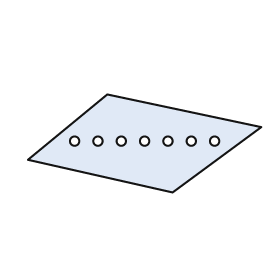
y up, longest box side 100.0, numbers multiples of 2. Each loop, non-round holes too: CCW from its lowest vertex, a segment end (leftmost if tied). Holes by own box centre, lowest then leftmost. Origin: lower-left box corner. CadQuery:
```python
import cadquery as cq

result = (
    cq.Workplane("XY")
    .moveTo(62.0, 0.0)
    .lineTo(100.0, 28.0)
    .lineTo(34.0, 42.0)
    .lineTo(0.0, 14.0)
    .close()
    .moveTo(20.0, 22.0)
    .circle(2.0)
    .moveTo(30.0, 22.0)
    .circle(2.0)
    .moveTo(40.0, 22.0)
    .circle(2.0)
    .moveTo(50.0, 22.0)
    .circle(2.0)
    .moveTo(60.0, 22.0)
    .circle(2.0)
    .moveTo(70.0, 22.0)
    .circle(2.0)
    .moveTo(80.0, 22.0)
    .circle(2.0)
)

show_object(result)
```